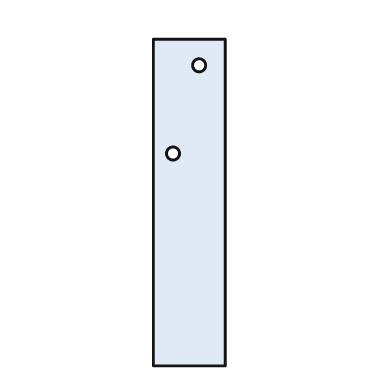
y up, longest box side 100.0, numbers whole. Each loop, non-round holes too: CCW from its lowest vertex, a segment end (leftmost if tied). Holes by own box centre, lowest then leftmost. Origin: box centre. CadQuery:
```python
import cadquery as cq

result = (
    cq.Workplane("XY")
    .moveTo(-11.0, -50.0)
    .lineTo(11.0, -50.0)
    .lineTo(11.0, 50.0)
    .lineTo(-11.0, 50.0)
    .close()
    .moveTo(-5.0, 15.0)
    .circle(2.0)
    .moveTo(3.0, 42.0)
    .circle(2.0)
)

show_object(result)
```